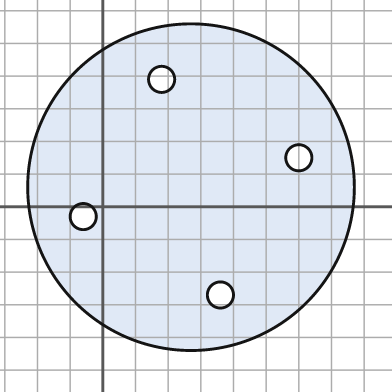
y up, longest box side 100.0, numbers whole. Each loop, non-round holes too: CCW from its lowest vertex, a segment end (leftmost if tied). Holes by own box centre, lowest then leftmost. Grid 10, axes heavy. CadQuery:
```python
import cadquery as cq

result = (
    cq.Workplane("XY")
    .moveTo(27.0, 6.0)
    .circle(50.0)
    .moveTo(36.0, -27.0)
    .circle(4.0)
    .moveTo(-6.0, -3.0)
    .circle(4.0)
    .moveTo(60.0, 15.0)
    .circle(4.0)
    .moveTo(18.0, 39.0)
    .circle(4.0)
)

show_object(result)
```